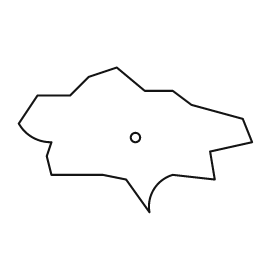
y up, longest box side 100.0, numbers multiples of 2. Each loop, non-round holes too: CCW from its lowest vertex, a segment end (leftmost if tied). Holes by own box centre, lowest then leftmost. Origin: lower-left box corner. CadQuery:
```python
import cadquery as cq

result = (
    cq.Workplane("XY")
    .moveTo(56.0, 0.0)
    .threePointArc((58.0, 10.0), (66.0, 16.0))
    .lineTo(84.0, 14.0)
    .lineTo(82.0, 26.0)
    .lineTo(100.0, 30.0)
    .lineTo(96.0, 40.0)
    .lineTo(74.0, 46.0)
    .lineTo(66.0, 52.0)
    .lineTo(54.0, 52.0)
    .lineTo(42.0, 62.0)
    .lineTo(30.0, 58.0)
    .lineTo(22.0, 50.0)
    .lineTo(8.0, 50.0)
    .lineTo(0.0, 38.0)
    .threePointArc((6.0, 32.0), (14.0, 30.0))
    .lineTo(12.0, 24.0)
    .lineTo(14.0, 16.0)
    .lineTo(36.0, 16.0)
    .lineTo(46.0, 14.0)
    .close()
    .moveTo(50.0, 32.0)
    .circle(2.0)
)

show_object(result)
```